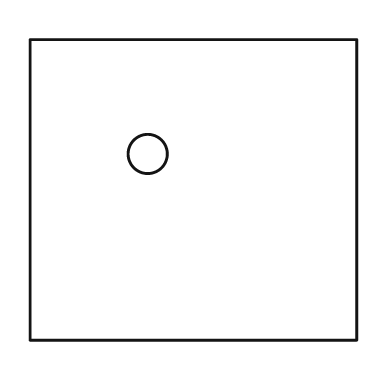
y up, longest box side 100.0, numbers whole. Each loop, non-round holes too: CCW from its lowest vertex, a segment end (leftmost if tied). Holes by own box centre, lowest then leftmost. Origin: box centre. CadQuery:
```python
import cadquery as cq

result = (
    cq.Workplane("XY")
    .moveTo(-50.0, -46.0)
    .lineTo(50.0, -46.0)
    .lineTo(50.0, 46.0)
    .lineTo(-50.0, 46.0)
    .close()
    .moveTo(-14.0, 11.0)
    .circle(6.0)
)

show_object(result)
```